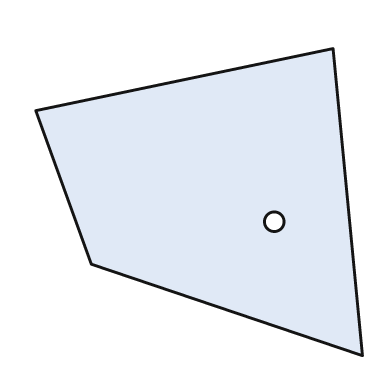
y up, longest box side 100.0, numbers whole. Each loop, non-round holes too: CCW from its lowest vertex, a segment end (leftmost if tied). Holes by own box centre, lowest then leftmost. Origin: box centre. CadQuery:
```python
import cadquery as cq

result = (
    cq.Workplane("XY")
    .moveTo(50.0, -47.0)
    .lineTo(41.0, 47.0)
    .lineTo(-50.0, 28.0)
    .lineTo(-33.0, -19.0)
    .close()
    .moveTo(23.0, -6.0)
    .circle(3.0)
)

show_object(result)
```